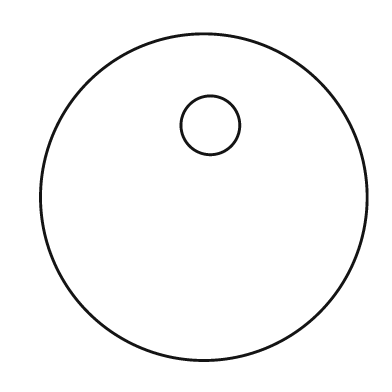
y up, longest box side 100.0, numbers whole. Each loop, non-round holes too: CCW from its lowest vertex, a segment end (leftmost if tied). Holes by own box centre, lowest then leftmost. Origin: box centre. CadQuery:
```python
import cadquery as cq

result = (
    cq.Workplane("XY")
    .moveTo(0.0, 0.0)
    .circle(50.0)
    .moveTo(2.0, 22.0)
    .circle(9.0)
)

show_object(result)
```